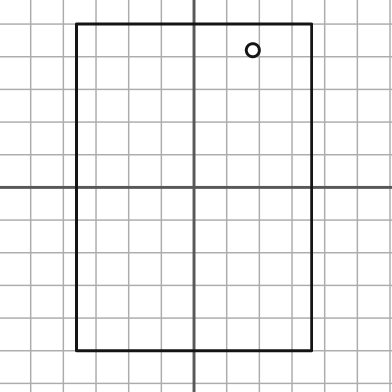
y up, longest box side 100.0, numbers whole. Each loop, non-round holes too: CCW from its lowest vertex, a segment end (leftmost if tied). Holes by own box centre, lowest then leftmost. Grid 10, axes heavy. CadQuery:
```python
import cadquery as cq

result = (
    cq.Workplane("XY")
    .moveTo(-36.0, -50.0)
    .lineTo(36.0, -50.0)
    .lineTo(36.0, 50.0)
    .lineTo(-36.0, 50.0)
    .close()
    .moveTo(18.0, 42.0)
    .circle(2.0)
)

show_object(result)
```